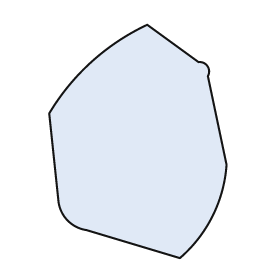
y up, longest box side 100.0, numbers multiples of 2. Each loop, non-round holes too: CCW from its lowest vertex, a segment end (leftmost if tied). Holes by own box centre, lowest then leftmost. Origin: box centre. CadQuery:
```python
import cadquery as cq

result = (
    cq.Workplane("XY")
    .moveTo(18.0, -50.0)
    .threePointArc((32.0, -32.0), (38.0, -10.0))
    .lineTo(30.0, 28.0)
    .threePointArc((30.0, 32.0), (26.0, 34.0))
    .lineTo(4.0, 50.0)
    .threePointArc((-20.0, 34.0), (-38.0, 12.0))
    .lineTo(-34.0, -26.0)
    .threePointArc((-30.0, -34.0), (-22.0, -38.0))
    .close()
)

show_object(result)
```